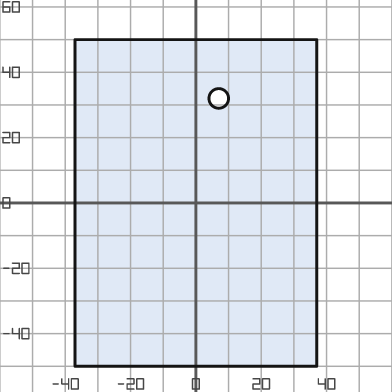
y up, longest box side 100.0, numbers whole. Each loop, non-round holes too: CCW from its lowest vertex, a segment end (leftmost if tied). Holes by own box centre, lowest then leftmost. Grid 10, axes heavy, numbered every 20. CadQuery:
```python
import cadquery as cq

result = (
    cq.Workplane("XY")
    .moveTo(-37.0, -50.0)
    .lineTo(37.0, -50.0)
    .lineTo(37.0, 50.0)
    .lineTo(-37.0, 50.0)
    .close()
    .moveTo(7.0, 32.0)
    .circle(3.0)
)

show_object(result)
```